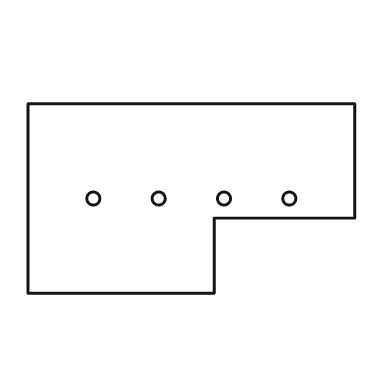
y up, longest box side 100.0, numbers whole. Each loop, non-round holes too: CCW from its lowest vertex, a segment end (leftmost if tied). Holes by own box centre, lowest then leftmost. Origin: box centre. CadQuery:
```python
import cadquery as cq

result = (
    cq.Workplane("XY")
    .moveTo(-50.0, -29.0)
    .lineTo(7.0, -29.0)
    .lineTo(7.0, -6.0)
    .lineTo(50.0, -6.0)
    .lineTo(50.0, 29.0)
    .lineTo(-50.0, 29.0)
    .close()
    .moveTo(-30.0, 0.0)
    .circle(2.0)
    .moveTo(-10.0, 0.0)
    .circle(2.0)
    .moveTo(10.0, 0.0)
    .circle(2.0)
    .moveTo(30.0, 0.0)
    .circle(2.0)
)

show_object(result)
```